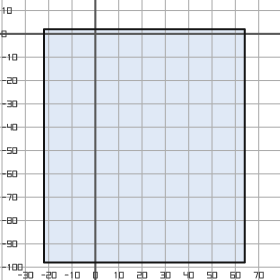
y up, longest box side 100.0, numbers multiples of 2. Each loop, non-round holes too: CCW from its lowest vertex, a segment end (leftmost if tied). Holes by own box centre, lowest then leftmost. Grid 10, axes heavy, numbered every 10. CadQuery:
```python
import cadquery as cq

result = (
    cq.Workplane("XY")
    .moveTo(-22.0, -98.0)
    .lineTo(64.0, -98.0)
    .lineTo(64.0, 2.0)
    .lineTo(-22.0, 2.0)
    .close()
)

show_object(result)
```